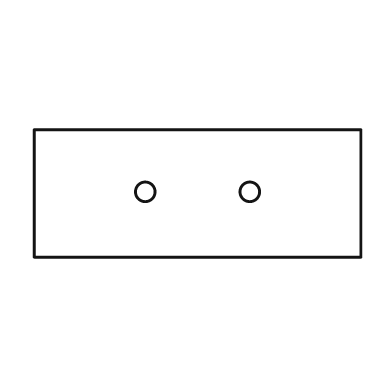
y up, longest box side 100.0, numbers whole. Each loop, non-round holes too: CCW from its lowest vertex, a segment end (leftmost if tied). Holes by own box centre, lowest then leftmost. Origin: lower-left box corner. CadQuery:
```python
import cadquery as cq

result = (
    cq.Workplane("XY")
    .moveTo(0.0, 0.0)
    .lineTo(100.0, 0.0)
    .lineTo(100.0, 39.0)
    .lineTo(0.0, 39.0)
    .close()
    .moveTo(34.0, 20.0)
    .circle(3.0)
    .moveTo(66.0, 20.0)
    .circle(3.0)
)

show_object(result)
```